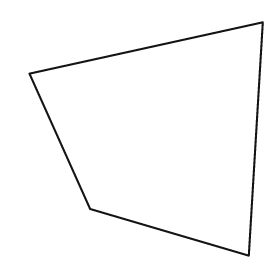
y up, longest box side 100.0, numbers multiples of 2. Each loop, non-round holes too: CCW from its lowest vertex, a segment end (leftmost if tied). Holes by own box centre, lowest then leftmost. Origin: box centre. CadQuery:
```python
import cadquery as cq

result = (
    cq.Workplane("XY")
    .moveTo(44.0, -50.0)
    .lineTo(50.0, 50.0)
    .lineTo(-50.0, 28.0)
    .lineTo(-24.0, -30.0)
    .close()
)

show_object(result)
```